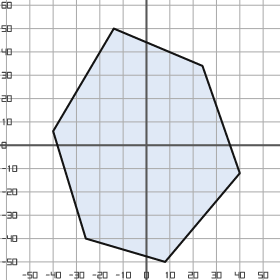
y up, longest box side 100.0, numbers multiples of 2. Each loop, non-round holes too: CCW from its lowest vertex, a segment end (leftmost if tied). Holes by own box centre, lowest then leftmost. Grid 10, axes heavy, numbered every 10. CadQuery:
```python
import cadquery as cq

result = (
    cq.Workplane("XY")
    .moveTo(8.0, -50.0)
    .lineTo(40.0, -12.0)
    .lineTo(24.0, 34.0)
    .lineTo(-14.0, 50.0)
    .lineTo(-40.0, 6.0)
    .lineTo(-26.0, -40.0)
    .close()
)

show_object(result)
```